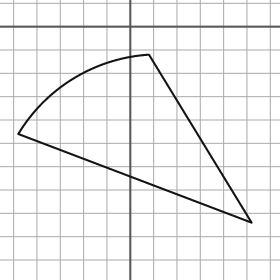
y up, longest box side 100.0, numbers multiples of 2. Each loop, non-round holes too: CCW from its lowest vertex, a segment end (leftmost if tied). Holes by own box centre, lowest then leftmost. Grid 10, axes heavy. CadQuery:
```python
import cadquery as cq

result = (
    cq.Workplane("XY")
    .moveTo(52.0, -84.0)
    .lineTo(8.0, -12.0)
    .threePointArc((-24.0, -22.0), (-48.0, -46.0))
    .close()
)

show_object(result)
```